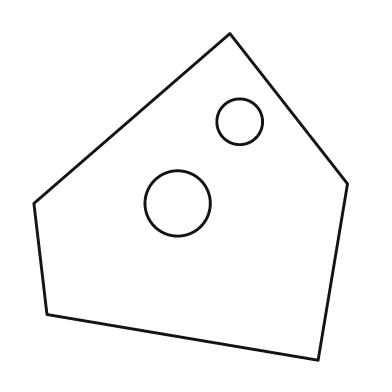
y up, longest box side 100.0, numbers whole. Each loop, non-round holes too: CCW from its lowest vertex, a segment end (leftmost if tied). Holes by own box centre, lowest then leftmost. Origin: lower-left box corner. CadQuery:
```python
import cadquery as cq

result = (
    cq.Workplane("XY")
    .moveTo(87.0, 0.0)
    .lineTo(96.0, 54.0)
    .lineTo(60.0, 100.0)
    .lineTo(0.0, 48.0)
    .lineTo(4.0, 14.0)
    .close()
    .moveTo(44.0, 48.0)
    .circle(10.0)
    .moveTo(63.0, 73.0)
    .circle(7.0)
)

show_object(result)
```